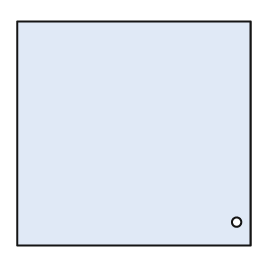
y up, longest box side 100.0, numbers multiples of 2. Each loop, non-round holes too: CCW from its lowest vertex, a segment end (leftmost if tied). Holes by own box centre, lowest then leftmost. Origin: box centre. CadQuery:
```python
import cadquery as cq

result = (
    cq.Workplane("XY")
    .moveTo(-50.0, -48.0)
    .lineTo(50.0, -48.0)
    .lineTo(50.0, 48.0)
    .lineTo(-50.0, 48.0)
    .close()
    .moveTo(44.0, -38.0)
    .circle(2.0)
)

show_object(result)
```